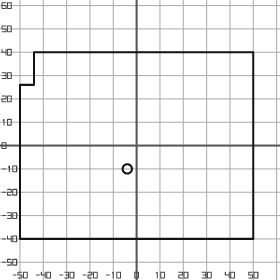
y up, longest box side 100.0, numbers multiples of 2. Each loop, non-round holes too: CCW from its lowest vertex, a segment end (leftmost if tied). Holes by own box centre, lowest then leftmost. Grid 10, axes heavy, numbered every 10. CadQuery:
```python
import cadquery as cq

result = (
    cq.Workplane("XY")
    .moveTo(-50.0, -40.0)
    .lineTo(50.0, -40.0)
    .lineTo(50.0, 40.0)
    .lineTo(-44.0, 40.0)
    .lineTo(-44.0, 26.0)
    .lineTo(-50.0, 26.0)
    .close()
    .moveTo(-4.0, -10.0)
    .circle(2.0)
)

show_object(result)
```